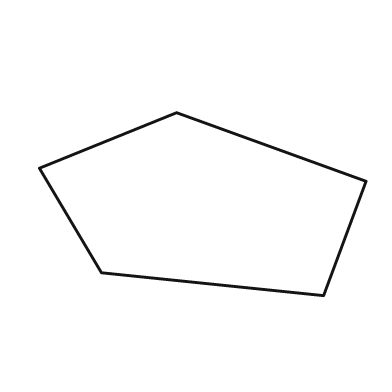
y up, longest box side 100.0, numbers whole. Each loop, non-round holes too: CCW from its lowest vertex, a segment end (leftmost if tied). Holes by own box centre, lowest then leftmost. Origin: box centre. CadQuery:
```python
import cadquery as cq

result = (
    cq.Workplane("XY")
    .moveTo(37.0, -28.0)
    .lineTo(50.0, 7.0)
    .lineTo(-8.0, 28.0)
    .lineTo(-50.0, 11.0)
    .lineTo(-31.0, -21.0)
    .close()
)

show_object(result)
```